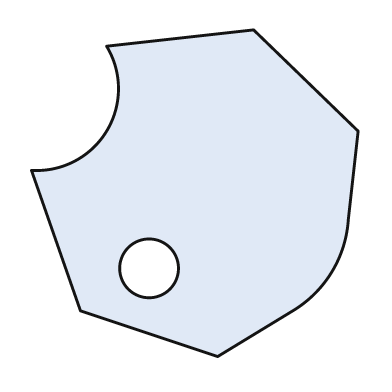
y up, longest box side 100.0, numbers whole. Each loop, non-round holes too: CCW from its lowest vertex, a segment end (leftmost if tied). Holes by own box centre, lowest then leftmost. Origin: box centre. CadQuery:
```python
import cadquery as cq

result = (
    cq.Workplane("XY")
    .moveTo(7.0, -50.0)
    .lineTo(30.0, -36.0)
    .threePointArc((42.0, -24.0), (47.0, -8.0))
    .lineTo(50.0, 19.0)
    .lineTo(18.0, 50.0)
    .lineTo(-27.0, 45.0)
    .threePointArc((-27.0, 19.0), (-50.0, 7.0))
    .lineTo(-35.0, -36.0)
    .close()
    .moveTo(-14.0, -23.0)
    .circle(9.0)
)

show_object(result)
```